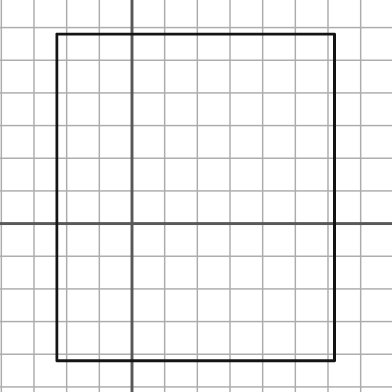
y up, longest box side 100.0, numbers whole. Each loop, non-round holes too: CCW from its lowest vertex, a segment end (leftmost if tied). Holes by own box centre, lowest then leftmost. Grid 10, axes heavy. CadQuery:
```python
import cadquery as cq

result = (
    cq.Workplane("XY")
    .moveTo(-23.0, -42.0)
    .lineTo(62.0, -42.0)
    .lineTo(62.0, 58.0)
    .lineTo(-23.0, 58.0)
    .close()
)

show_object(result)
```